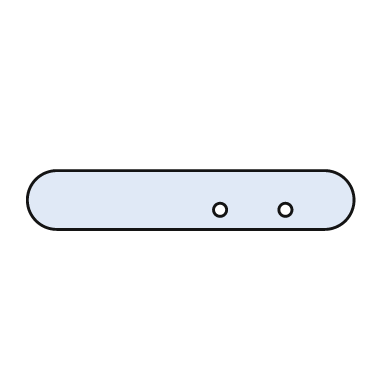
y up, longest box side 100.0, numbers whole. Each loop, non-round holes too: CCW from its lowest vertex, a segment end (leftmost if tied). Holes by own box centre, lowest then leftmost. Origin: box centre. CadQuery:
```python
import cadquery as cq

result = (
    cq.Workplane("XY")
    .moveTo(-41.0, -9.0)
    .lineTo(41.0, -9.0)
    .threePointArc((50.0, 0.0), (41.0, 9.0))
    .lineTo(-41.0, 9.0)
    .threePointArc((-50.0, 0.0), (-41.0, -9.0))
    .close()
    .moveTo(9.0, -3.0)
    .circle(2.0)
    .moveTo(29.0, -3.0)
    .circle(2.0)
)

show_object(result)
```